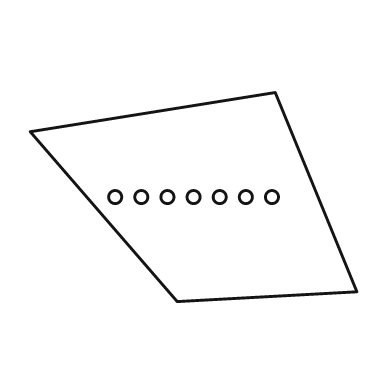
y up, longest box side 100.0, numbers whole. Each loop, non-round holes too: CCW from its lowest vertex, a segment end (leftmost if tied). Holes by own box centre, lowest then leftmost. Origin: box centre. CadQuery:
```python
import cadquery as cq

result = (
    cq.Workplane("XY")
    .moveTo(-5.0, -32.0)
    .lineTo(50.0, -29.0)
    .lineTo(25.0, 32.0)
    .lineTo(-50.0, 20.0)
    .close()
    .moveTo(-24.0, 0.0)
    .circle(2.0)
    .moveTo(-16.0, 0.0)
    .circle(2.0)
    .moveTo(-8.0, 0.0)
    .circle(2.0)
    .moveTo(0.0, 0.0)
    .circle(2.0)
    .moveTo(8.0, 0.0)
    .circle(2.0)
    .moveTo(16.0, 0.0)
    .circle(2.0)
    .moveTo(24.0, 0.0)
    .circle(2.0)
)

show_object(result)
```